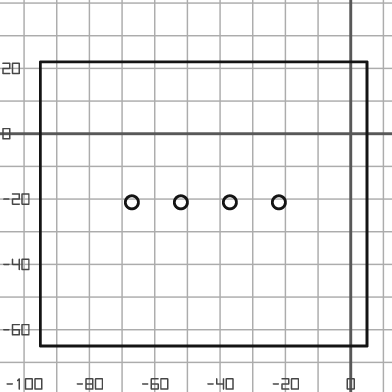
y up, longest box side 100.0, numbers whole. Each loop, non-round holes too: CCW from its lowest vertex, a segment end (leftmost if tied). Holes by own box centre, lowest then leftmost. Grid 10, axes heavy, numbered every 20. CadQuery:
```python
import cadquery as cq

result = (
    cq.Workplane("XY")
    .moveTo(-95.0, -65.0)
    .lineTo(5.0, -65.0)
    .lineTo(5.0, 22.0)
    .lineTo(-95.0, 22.0)
    .close()
    .moveTo(-67.0, -21.0)
    .circle(2.0)
    .moveTo(-52.0, -21.0)
    .circle(2.0)
    .moveTo(-37.0, -21.0)
    .circle(2.0)
    .moveTo(-22.0, -21.0)
    .circle(2.0)
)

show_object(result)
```